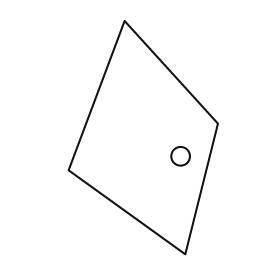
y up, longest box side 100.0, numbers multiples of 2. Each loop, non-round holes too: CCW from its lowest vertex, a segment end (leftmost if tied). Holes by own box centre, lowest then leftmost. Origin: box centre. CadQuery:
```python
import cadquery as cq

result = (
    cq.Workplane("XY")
    .moveTo(18.0, -50.0)
    .lineTo(32.0, 6.0)
    .lineTo(-8.0, 50.0)
    .lineTo(-32.0, -14.0)
    .close()
    .moveTo(16.0, -8.0)
    .circle(4.0)
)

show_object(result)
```